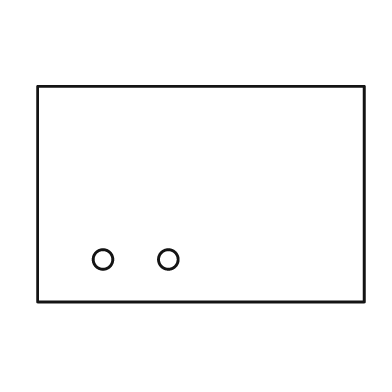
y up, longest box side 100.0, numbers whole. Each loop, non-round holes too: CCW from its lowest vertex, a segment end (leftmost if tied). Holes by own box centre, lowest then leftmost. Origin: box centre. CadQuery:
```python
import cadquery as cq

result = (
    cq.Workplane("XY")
    .moveTo(-50.0, -33.0)
    .lineTo(50.0, -33.0)
    .lineTo(50.0, 33.0)
    .lineTo(-50.0, 33.0)
    .close()
    .moveTo(-30.0, -20.0)
    .circle(3.0)
    .moveTo(-10.0, -20.0)
    .circle(3.0)
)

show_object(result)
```